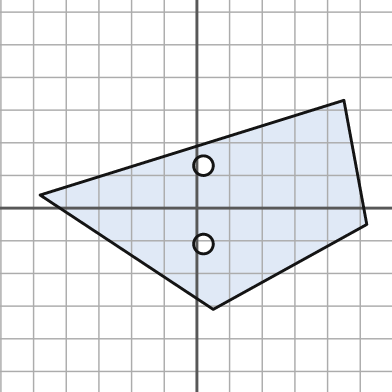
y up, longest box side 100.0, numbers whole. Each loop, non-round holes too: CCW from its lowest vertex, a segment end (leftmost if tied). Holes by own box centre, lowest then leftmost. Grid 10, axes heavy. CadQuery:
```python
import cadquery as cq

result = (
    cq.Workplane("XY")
    .moveTo(5.0, -31.0)
    .lineTo(52.0, -5.0)
    .lineTo(45.0, 33.0)
    .lineTo(-48.0, 4.0)
    .close()
    .moveTo(2.0, -11.0)
    .circle(3.0)
    .moveTo(2.0, 13.0)
    .circle(3.0)
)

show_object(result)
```